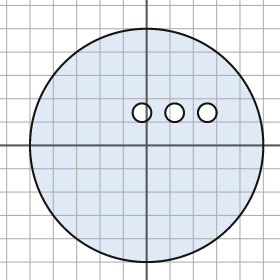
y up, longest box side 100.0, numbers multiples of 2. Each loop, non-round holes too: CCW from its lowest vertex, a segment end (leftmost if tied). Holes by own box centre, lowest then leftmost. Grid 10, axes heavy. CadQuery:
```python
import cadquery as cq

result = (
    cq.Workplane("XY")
    .moveTo(0.0, 0.0)
    .circle(50.0)
    .moveTo(-2.0, 14.0)
    .circle(4.0)
    .moveTo(12.0, 14.0)
    .circle(4.0)
    .moveTo(26.0, 14.0)
    .circle(4.0)
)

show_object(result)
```